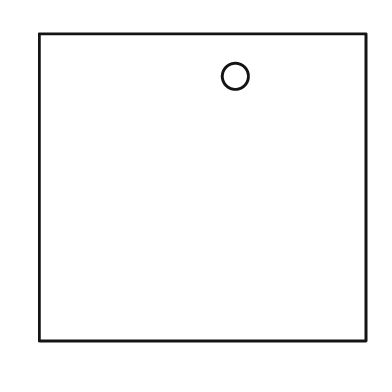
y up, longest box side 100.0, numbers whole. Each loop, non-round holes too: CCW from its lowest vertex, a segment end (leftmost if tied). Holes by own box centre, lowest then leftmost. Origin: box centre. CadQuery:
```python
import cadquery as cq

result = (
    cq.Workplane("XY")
    .moveTo(-50.0, -47.0)
    .lineTo(50.0, -47.0)
    .lineTo(50.0, 47.0)
    .lineTo(-50.0, 47.0)
    .close()
    .moveTo(10.0, 34.0)
    .circle(4.0)
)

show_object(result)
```